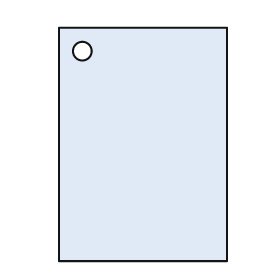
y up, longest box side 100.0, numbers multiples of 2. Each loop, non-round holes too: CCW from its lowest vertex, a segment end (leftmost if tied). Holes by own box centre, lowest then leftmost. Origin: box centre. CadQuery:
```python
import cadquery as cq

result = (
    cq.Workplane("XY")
    .moveTo(-36.0, -50.0)
    .lineTo(36.0, -50.0)
    .lineTo(36.0, 50.0)
    .lineTo(-36.0, 50.0)
    .close()
    .moveTo(-26.0, 40.0)
    .circle(4.0)
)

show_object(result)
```